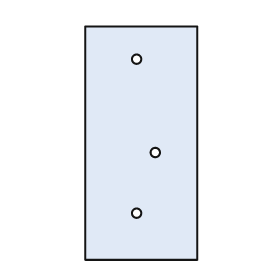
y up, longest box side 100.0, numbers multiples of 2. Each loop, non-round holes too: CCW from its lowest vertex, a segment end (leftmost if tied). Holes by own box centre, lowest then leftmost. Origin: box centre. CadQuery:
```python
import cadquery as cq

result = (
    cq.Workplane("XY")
    .moveTo(-24.0, -50.0)
    .lineTo(24.0, -50.0)
    .lineTo(24.0, 50.0)
    .lineTo(-24.0, 50.0)
    .close()
    .moveTo(-2.0, -30.0)
    .circle(2.0)
    .moveTo(6.0, -4.0)
    .circle(2.0)
    .moveTo(-2.0, 36.0)
    .circle(2.0)
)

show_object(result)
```